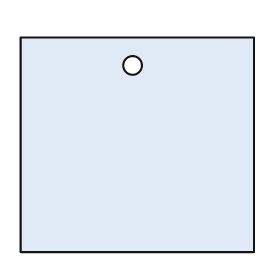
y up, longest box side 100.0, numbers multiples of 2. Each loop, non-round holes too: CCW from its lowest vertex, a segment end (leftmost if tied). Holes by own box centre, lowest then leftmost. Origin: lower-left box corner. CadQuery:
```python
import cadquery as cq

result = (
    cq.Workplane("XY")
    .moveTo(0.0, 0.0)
    .lineTo(100.0, 0.0)
    .lineTo(100.0, 92.0)
    .lineTo(0.0, 92.0)
    .close()
    .moveTo(48.0, 80.0)
    .circle(4.0)
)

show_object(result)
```